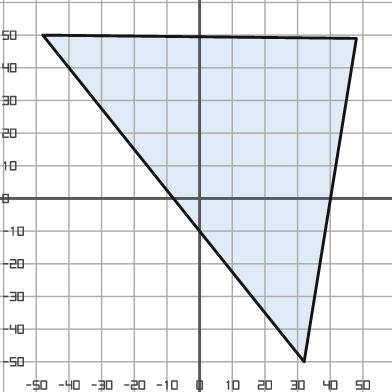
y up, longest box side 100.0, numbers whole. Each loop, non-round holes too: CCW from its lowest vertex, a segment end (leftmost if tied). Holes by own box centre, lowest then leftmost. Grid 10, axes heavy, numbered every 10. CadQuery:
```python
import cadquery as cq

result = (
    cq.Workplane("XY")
    .moveTo(32.0, -50.0)
    .lineTo(48.0, 49.0)
    .lineTo(-48.0, 50.0)
    .close()
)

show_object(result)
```